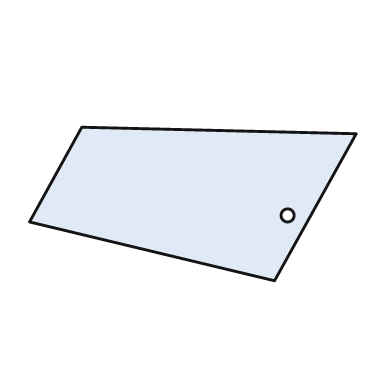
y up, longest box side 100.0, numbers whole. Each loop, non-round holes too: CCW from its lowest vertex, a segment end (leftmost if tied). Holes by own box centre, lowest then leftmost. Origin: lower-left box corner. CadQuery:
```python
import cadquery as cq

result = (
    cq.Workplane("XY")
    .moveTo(75.0, 0.0)
    .lineTo(100.0, 45.0)
    .lineTo(16.0, 47.0)
    .lineTo(0.0, 18.0)
    .close()
    .moveTo(79.0, 20.0)
    .circle(2.0)
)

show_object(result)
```